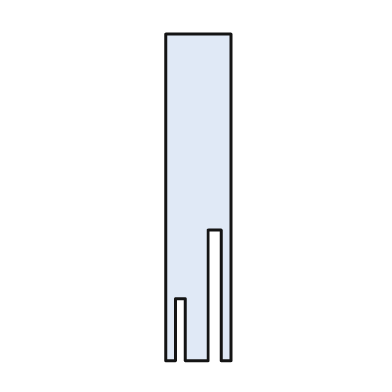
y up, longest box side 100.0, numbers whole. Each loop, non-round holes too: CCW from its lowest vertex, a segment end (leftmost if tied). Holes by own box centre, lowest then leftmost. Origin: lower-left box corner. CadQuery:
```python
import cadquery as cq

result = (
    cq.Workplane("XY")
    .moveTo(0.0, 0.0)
    .lineTo(3.0, 0.0)
    .lineTo(3.0, 19.0)
    .lineTo(6.0, 19.0)
    .lineTo(6.0, 0.0)
    .lineTo(13.0, 0.0)
    .lineTo(13.0, 40.0)
    .lineTo(17.0, 40.0)
    .lineTo(17.0, 0.0)
    .lineTo(20.0, 0.0)
    .lineTo(20.0, 100.0)
    .lineTo(0.0, 100.0)
    .close()
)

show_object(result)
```